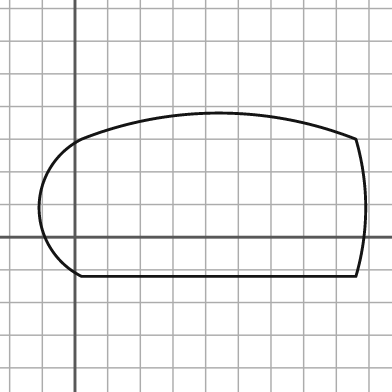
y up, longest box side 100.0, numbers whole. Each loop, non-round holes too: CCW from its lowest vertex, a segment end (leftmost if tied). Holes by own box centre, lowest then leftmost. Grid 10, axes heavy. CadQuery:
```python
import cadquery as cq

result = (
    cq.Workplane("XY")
    .moveTo(2.0, -12.0)
    .lineTo(86.0, -12.0)
    .threePointArc((89.0, 9.0), (86.0, 30.0))
    .threePointArc((44.0, 38.0), (2.0, 30.0))
    .threePointArc((-11.0, 9.0), (2.0, -12.0))
    .close()
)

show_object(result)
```